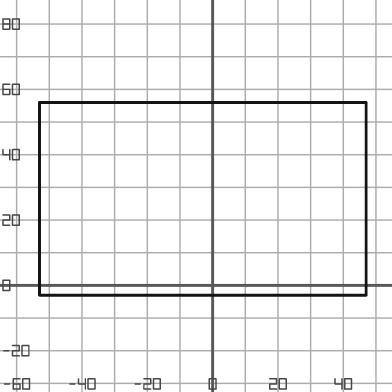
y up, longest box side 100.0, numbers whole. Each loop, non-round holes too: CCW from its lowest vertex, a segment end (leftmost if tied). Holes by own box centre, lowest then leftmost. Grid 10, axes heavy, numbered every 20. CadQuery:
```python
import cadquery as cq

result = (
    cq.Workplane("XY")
    .moveTo(-53.0, -3.0)
    .lineTo(47.0, -3.0)
    .lineTo(47.0, 56.0)
    .lineTo(-53.0, 56.0)
    .close()
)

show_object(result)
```